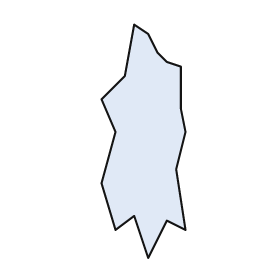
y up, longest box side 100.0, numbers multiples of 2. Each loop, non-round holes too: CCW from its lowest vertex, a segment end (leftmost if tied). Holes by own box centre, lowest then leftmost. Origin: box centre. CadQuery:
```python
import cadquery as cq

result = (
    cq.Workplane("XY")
    .moveTo(2.0, -50.0)
    .lineTo(10.0, -34.0)
    .lineTo(18.0, -38.0)
    .lineTo(14.0, -12.0)
    .lineTo(18.0, 4.0)
    .lineTo(16.0, 14.0)
    .lineTo(16.0, 32.0)
    .lineTo(10.0, 34.0)
    .lineTo(6.0, 38.0)
    .lineTo(2.0, 46.0)
    .lineTo(-4.0, 50.0)
    .lineTo(-8.0, 28.0)
    .lineTo(-18.0, 18.0)
    .lineTo(-12.0, 4.0)
    .lineTo(-18.0, -18.0)
    .lineTo(-12.0, -38.0)
    .lineTo(-4.0, -32.0)
    .close()
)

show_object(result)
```